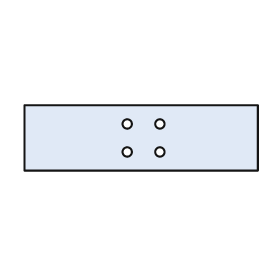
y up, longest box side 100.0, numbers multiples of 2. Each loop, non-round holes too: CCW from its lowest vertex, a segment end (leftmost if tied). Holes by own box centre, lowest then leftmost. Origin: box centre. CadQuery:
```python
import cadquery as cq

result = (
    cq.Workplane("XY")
    .moveTo(-50.0, -14.0)
    .lineTo(50.0, -14.0)
    .lineTo(50.0, 14.0)
    .lineTo(-50.0, 14.0)
    .close()
    .moveTo(-6.0, -6.0)
    .circle(2.0)
    .moveTo(8.0, -6.0)
    .circle(2.0)
    .moveTo(-6.0, 6.0)
    .circle(2.0)
    .moveTo(8.0, 6.0)
    .circle(2.0)
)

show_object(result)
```